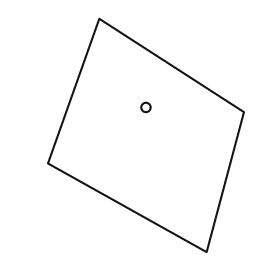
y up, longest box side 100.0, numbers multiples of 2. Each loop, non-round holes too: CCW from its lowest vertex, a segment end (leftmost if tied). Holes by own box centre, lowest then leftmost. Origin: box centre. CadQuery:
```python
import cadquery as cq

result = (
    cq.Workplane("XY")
    .moveTo(26.0, -50.0)
    .lineTo(42.0, 10.0)
    .lineTo(-20.0, 50.0)
    .lineTo(-42.0, -12.0)
    .close()
    .moveTo(0.0, 12.0)
    .circle(2.0)
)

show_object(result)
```